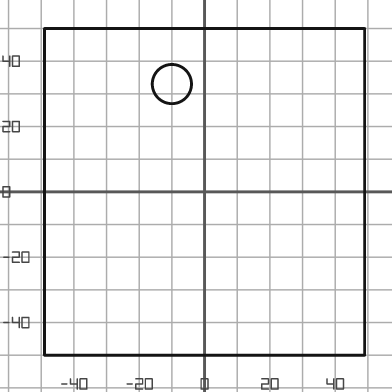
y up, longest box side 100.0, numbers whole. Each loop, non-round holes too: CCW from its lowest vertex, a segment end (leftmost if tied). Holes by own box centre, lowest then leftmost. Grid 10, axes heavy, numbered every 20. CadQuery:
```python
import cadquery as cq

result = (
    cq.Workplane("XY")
    .moveTo(-49.0, -50.0)
    .lineTo(49.0, -50.0)
    .lineTo(49.0, 50.0)
    .lineTo(-49.0, 50.0)
    .close()
    .moveTo(-10.0, 33.0)
    .circle(6.0)
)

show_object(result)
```